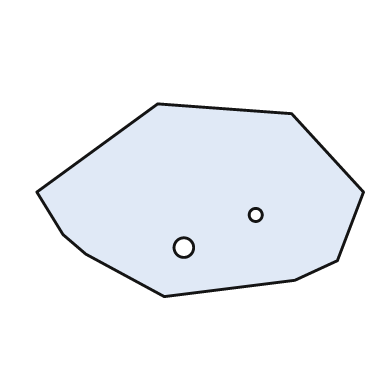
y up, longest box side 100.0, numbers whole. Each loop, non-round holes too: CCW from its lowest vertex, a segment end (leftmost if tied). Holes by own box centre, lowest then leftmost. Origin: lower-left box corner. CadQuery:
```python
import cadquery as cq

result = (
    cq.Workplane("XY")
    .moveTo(39.0, 0.0)
    .lineTo(79.0, 5.0)
    .lineTo(92.0, 11.0)
    .lineTo(100.0, 32.0)
    .lineTo(78.0, 56.0)
    .lineTo(37.0, 59.0)
    .lineTo(0.0, 32.0)
    .lineTo(8.0, 19.0)
    .lineTo(15.0, 13.0)
    .close()
    .moveTo(45.0, 15.0)
    .circle(3.0)
    .moveTo(67.0, 25.0)
    .circle(2.0)
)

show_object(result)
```